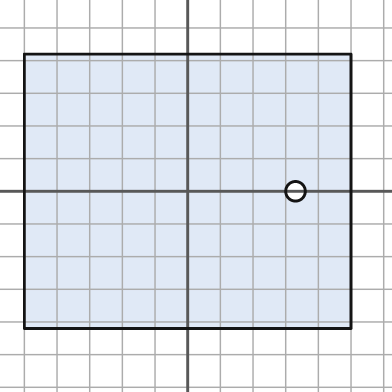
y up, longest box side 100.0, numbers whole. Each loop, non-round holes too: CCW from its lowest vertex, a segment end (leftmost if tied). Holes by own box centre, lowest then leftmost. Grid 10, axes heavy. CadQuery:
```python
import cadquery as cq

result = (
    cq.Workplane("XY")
    .moveTo(-50.0, -42.0)
    .lineTo(50.0, -42.0)
    .lineTo(50.0, 42.0)
    .lineTo(-50.0, 42.0)
    .close()
    .moveTo(33.0, 0.0)
    .circle(3.0)
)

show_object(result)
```